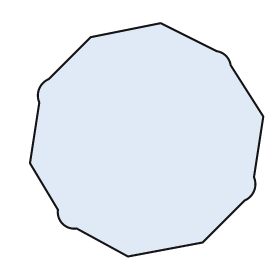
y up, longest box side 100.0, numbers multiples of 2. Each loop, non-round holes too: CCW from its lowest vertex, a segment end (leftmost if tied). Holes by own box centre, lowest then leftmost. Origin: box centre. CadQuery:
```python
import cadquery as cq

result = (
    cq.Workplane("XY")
    .moveTo(-8.0, -50.0)
    .lineTo(24.0, -44.0)
    .lineTo(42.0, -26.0)
    .threePointArc((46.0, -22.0), (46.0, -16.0))
    .lineTo(50.0, 10.0)
    .lineTo(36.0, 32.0)
    .threePointArc((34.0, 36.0), (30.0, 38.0))
    .lineTo(6.0, 50.0)
    .lineTo(-24.0, 44.0)
    .lineTo(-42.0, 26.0)
    .threePointArc((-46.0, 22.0), (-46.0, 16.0))
    .lineTo(-50.0, -10.0)
    .lineTo(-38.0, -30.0)
    .threePointArc((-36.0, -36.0), (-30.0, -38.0))
    .close()
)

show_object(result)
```